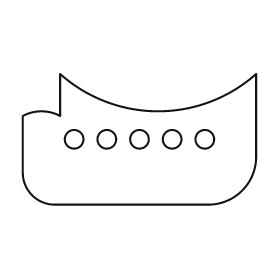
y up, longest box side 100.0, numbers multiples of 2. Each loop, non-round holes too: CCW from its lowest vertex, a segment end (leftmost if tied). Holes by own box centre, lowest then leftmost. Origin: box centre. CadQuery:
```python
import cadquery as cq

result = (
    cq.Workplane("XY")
    .moveTo(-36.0, -28.0)
    .lineTo(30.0, -28.0)
    .threePointArc((44.0, -22.0), (50.0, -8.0))
    .lineTo(50.0, 28.0)
    .threePointArc((8.0, 12.0), (-34.0, 28.0))
    .lineTo(-34.0, 10.0)
    .threePointArc((-42.0, 12.0), (-50.0, 10.0))
    .lineTo(-50.0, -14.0)
    .threePointArc((-46.0, -24.0), (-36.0, -28.0))
    .close()
    .moveTo(-28.0, 0.0)
    .circle(4.0)
    .moveTo(-14.0, 0.0)
    .circle(4.0)
    .moveTo(0.0, 0.0)
    .circle(4.0)
    .moveTo(14.0, 0.0)
    .circle(4.0)
    .moveTo(28.0, 0.0)
    .circle(4.0)
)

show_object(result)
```